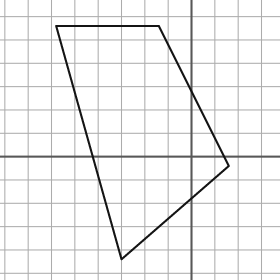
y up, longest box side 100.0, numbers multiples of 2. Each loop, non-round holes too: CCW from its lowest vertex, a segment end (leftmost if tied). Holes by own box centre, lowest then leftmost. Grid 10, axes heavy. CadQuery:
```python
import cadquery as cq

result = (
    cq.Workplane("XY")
    .moveTo(-30.0, -44.0)
    .lineTo(16.0, -4.0)
    .lineTo(-14.0, 56.0)
    .lineTo(-58.0, 56.0)
    .close()
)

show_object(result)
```